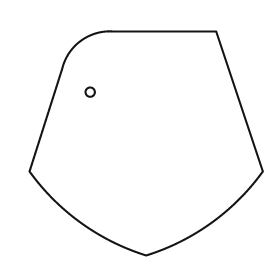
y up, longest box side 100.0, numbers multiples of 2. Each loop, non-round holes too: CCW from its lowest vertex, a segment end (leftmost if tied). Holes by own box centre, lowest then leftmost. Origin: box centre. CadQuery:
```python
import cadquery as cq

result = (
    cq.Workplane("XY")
    .moveTo(0.0, -48.0)
    .threePointArc((28.0, -34.0), (50.0, -12.0))
    .lineTo(30.0, 48.0)
    .lineTo(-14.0, 48.0)
    .threePointArc((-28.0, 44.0), (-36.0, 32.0))
    .lineTo(-50.0, -12.0)
    .threePointArc((-28.0, -34.0), (0.0, -48.0))
    .close()
    .moveTo(-24.0, 22.0)
    .circle(2.0)
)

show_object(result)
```